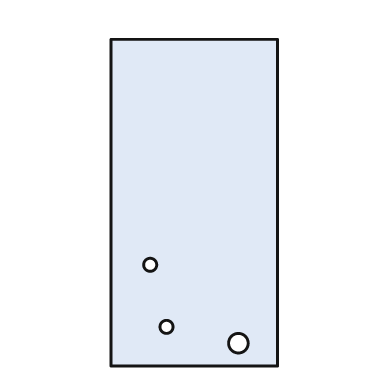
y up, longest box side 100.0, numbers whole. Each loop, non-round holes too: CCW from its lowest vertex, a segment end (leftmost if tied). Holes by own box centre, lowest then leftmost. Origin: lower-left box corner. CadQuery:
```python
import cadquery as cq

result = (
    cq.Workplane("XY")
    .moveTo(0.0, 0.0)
    .lineTo(51.0, 0.0)
    .lineTo(51.0, 100.0)
    .lineTo(0.0, 100.0)
    .close()
    .moveTo(39.0, 7.0)
    .circle(3.0)
    .moveTo(17.0, 12.0)
    .circle(2.0)
    .moveTo(12.0, 31.0)
    .circle(2.0)
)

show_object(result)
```